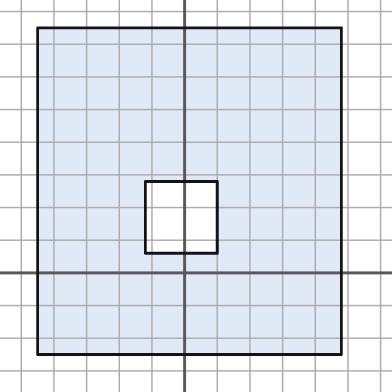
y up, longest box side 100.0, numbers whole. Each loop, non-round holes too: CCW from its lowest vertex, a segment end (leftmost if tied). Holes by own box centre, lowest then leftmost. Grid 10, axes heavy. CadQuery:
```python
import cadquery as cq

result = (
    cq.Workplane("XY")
    .moveTo(-45.0, -25.0)
    .lineTo(48.0, -25.0)
    .lineTo(48.0, 75.0)
    .lineTo(-45.0, 75.0)
    .close()
    .moveTo(-12.0, 6.0)
    .lineTo(10.0, 6.0)
    .lineTo(10.0, 28.0)
    .lineTo(-12.0, 28.0)
    .close()
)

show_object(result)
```